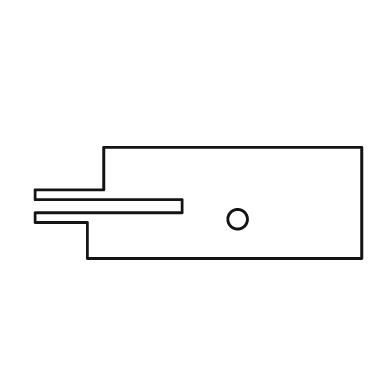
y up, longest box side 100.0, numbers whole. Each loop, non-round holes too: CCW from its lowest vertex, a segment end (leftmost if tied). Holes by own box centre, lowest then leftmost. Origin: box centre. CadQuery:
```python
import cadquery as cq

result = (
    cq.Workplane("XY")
    .moveTo(-34.0, -17.0)
    .lineTo(50.0, -17.0)
    .lineTo(50.0, 17.0)
    .lineTo(-29.0, 17.0)
    .lineTo(-29.0, 4.0)
    .lineTo(-50.0, 4.0)
    .lineTo(-50.0, 1.0)
    .lineTo(-5.0, 1.0)
    .lineTo(-5.0, -3.0)
    .lineTo(-50.0, -3.0)
    .lineTo(-50.0, -6.0)
    .lineTo(-34.0, -6.0)
    .close()
    .moveTo(12.0, -5.0)
    .circle(3.0)
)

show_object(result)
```